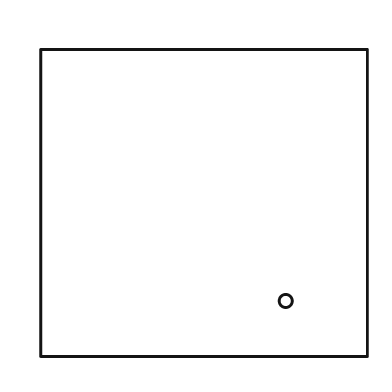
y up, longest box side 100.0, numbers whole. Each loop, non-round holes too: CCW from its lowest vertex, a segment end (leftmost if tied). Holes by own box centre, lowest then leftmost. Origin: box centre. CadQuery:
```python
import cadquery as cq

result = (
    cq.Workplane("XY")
    .moveTo(-50.0, -47.0)
    .lineTo(50.0, -47.0)
    .lineTo(50.0, 47.0)
    .lineTo(-50.0, 47.0)
    .close()
    .moveTo(25.0, -30.0)
    .circle(2.0)
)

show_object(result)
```